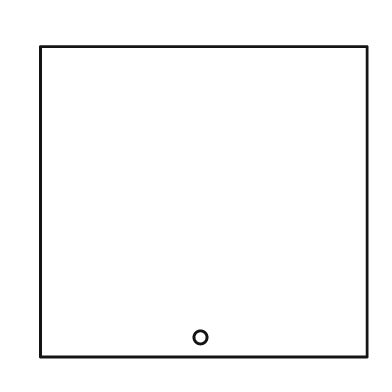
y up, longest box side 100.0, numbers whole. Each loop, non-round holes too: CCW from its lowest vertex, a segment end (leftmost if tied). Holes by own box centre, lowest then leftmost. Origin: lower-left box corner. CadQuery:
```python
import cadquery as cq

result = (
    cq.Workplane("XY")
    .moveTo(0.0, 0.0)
    .lineTo(100.0, 0.0)
    .lineTo(100.0, 95.0)
    .lineTo(0.0, 95.0)
    .close()
    .moveTo(49.0, 6.0)
    .circle(2.0)
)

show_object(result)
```